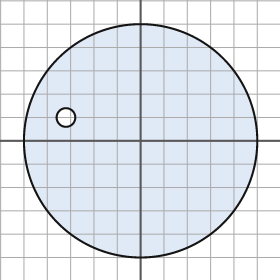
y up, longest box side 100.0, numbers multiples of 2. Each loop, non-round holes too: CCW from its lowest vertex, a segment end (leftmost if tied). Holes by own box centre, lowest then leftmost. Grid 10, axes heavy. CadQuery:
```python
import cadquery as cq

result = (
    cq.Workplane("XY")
    .moveTo(0.0, 0.0)
    .circle(50.0)
    .moveTo(-32.0, 10.0)
    .circle(4.0)
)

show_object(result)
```